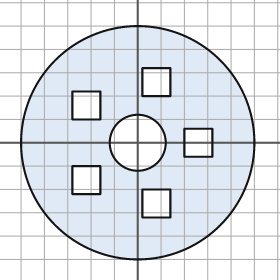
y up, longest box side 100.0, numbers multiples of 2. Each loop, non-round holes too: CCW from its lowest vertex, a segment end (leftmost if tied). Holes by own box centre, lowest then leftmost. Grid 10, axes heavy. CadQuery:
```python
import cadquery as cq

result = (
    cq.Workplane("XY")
    .moveTo(0.0, 0.0)
    .circle(50.0)
    .moveTo(2.0, -32.0)
    .lineTo(14.0, -32.0)
    .lineTo(14.0, -20.0)
    .lineTo(2.0, -20.0)
    .close()
    .moveTo(-28.0, -22.0)
    .lineTo(-16.0, -22.0)
    .lineTo(-16.0, -10.0)
    .lineTo(-28.0, -10.0)
    .close()
    .moveTo(0.0, 0.0)
    .circle(12.0)
    .moveTo(20.0, -6.0)
    .lineTo(32.0, -6.0)
    .lineTo(32.0, 6.0)
    .lineTo(20.0, 6.0)
    .close()
    .moveTo(-28.0, 10.0)
    .lineTo(-16.0, 10.0)
    .lineTo(-16.0, 22.0)
    .lineTo(-28.0, 22.0)
    .close()
    .moveTo(2.0, 20.0)
    .lineTo(14.0, 20.0)
    .lineTo(14.0, 32.0)
    .lineTo(2.0, 32.0)
    .close()
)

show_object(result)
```